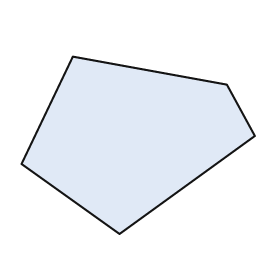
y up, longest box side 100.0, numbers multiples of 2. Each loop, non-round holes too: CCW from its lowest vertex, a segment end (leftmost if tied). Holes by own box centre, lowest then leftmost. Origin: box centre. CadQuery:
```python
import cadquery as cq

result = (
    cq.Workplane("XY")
    .moveTo(-8.0, -38.0)
    .lineTo(50.0, 4.0)
    .lineTo(38.0, 26.0)
    .lineTo(-28.0, 38.0)
    .lineTo(-50.0, -8.0)
    .close()
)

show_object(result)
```